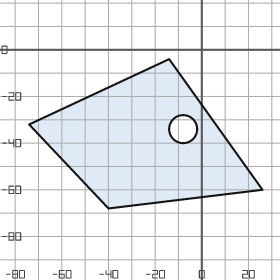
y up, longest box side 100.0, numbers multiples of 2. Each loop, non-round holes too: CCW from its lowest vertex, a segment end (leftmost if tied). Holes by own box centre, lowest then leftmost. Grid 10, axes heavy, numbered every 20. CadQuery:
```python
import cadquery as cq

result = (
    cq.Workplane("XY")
    .moveTo(-40.0, -68.0)
    .lineTo(26.0, -60.0)
    .lineTo(-14.0, -4.0)
    .lineTo(-74.0, -32.0)
    .close()
    .moveTo(-8.0, -34.0)
    .circle(6.0)
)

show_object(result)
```